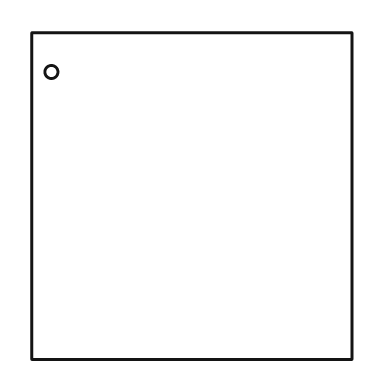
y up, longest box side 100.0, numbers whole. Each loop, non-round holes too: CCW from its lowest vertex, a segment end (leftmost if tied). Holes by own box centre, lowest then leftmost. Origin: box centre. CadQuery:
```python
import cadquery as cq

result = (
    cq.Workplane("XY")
    .moveTo(-49.0, -50.0)
    .lineTo(49.0, -50.0)
    .lineTo(49.0, 50.0)
    .lineTo(-49.0, 50.0)
    .close()
    .moveTo(-43.0, 38.0)
    .circle(2.0)
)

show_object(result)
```